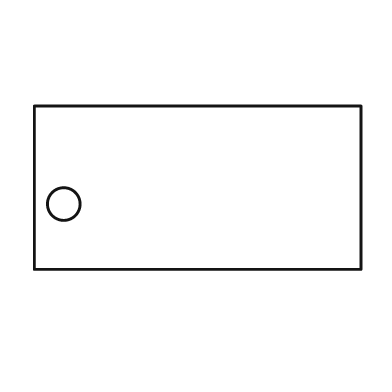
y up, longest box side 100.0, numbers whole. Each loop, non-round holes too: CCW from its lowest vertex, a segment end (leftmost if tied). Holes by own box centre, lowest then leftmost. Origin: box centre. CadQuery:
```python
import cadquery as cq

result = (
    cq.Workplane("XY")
    .moveTo(-50.0, -25.0)
    .lineTo(50.0, -25.0)
    .lineTo(50.0, 25.0)
    .lineTo(-50.0, 25.0)
    .close()
    .moveTo(-41.0, -5.0)
    .circle(5.0)
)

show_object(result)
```